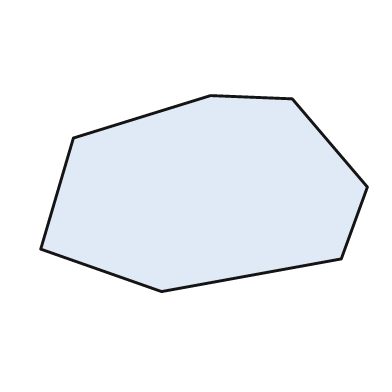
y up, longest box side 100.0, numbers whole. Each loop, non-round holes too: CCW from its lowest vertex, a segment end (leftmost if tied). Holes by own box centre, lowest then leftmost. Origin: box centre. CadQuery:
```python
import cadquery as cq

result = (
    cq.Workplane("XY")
    .moveTo(-13.0, -30.0)
    .lineTo(42.0, -20.0)
    .lineTo(50.0, 2.0)
    .lineTo(27.0, 29.0)
    .lineTo(2.0, 30.0)
    .lineTo(-40.0, 17.0)
    .lineTo(-50.0, -17.0)
    .close()
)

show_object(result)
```